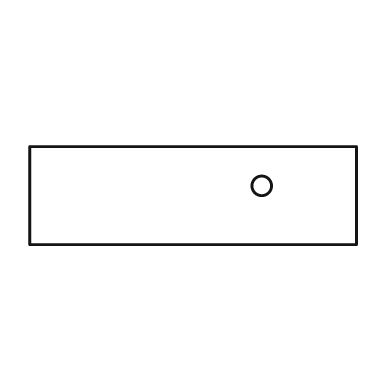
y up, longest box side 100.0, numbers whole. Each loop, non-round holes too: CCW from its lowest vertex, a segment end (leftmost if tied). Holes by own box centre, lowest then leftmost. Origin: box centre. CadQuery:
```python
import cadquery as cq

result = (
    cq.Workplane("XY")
    .moveTo(-50.0, -15.0)
    .lineTo(50.0, -15.0)
    .lineTo(50.0, 15.0)
    .lineTo(-50.0, 15.0)
    .close()
    .moveTo(21.0, 3.0)
    .circle(3.0)
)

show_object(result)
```